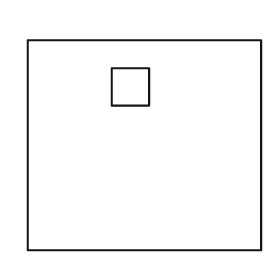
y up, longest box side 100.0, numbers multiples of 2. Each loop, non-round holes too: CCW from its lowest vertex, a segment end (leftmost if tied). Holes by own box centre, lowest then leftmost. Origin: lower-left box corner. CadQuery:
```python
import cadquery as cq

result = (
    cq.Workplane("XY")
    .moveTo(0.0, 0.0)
    .lineTo(100.0, 0.0)
    .lineTo(100.0, 90.0)
    .lineTo(0.0, 90.0)
    .close()
    .moveTo(36.0, 62.0)
    .lineTo(52.0, 62.0)
    .lineTo(52.0, 78.0)
    .lineTo(36.0, 78.0)
    .close()
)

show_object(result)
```